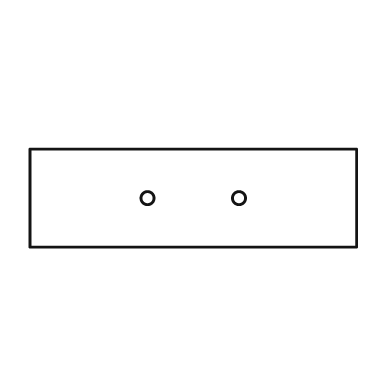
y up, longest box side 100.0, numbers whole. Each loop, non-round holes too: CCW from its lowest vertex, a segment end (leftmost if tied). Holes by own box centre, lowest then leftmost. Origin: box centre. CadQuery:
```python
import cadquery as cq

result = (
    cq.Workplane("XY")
    .moveTo(-50.0, -15.0)
    .lineTo(50.0, -15.0)
    .lineTo(50.0, 15.0)
    .lineTo(-50.0, 15.0)
    .close()
    .moveTo(-14.0, 0.0)
    .circle(2.0)
    .moveTo(14.0, 0.0)
    .circle(2.0)
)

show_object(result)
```